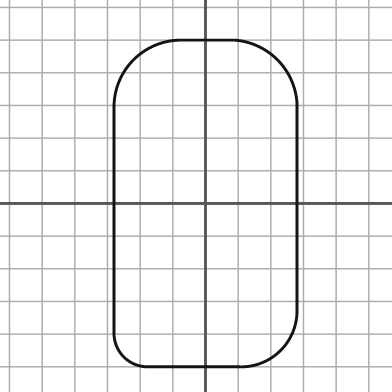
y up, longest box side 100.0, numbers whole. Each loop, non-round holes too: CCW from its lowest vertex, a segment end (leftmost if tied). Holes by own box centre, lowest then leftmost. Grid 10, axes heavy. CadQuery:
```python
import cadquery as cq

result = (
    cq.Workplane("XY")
    .moveTo(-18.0, -50.0)
    .lineTo(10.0, -50.0)
    .threePointArc((23.0, -45.0), (28.0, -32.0))
    .lineTo(28.0, 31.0)
    .threePointArc((22.0, 44.0), (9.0, 50.0))
    .lineTo(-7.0, 50.0)
    .threePointArc((-22.0, 44.0), (-28.0, 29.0))
    .lineTo(-28.0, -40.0)
    .threePointArc((-25.0, -47.0), (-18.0, -50.0))
    .close()
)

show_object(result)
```